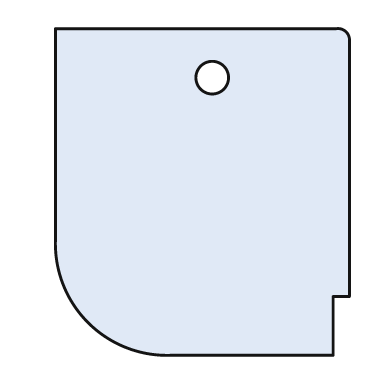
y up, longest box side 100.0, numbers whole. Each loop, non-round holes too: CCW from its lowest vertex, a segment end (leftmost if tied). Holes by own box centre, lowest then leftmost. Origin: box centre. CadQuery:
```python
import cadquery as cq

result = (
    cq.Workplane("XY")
    .moveTo(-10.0, -50.0)
    .lineTo(40.0, -50.0)
    .lineTo(40.0, -32.0)
    .lineTo(45.0, -32.0)
    .lineTo(45.0, 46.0)
    .threePointArc((44.0, 49.0), (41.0, 50.0))
    .lineTo(-45.0, 50.0)
    .lineTo(-45.0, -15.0)
    .threePointArc((-35.0, -40.0), (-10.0, -50.0))
    .close()
    .moveTo(3.0, 35.0)
    .circle(5.0)
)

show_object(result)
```